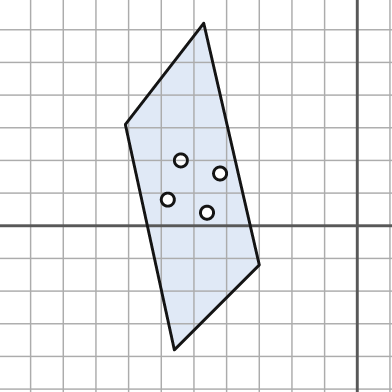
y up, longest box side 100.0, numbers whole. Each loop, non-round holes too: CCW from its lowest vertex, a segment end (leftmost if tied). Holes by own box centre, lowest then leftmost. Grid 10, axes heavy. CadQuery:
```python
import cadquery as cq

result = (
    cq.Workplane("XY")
    .moveTo(-56.0, -38.0)
    .lineTo(-30.0, -12.0)
    .lineTo(-47.0, 62.0)
    .lineTo(-71.0, 31.0)
    .close()
    .moveTo(-46.0, 4.0)
    .circle(2.0)
    .moveTo(-58.0, 8.0)
    .circle(2.0)
    .moveTo(-42.0, 16.0)
    .circle(2.0)
    .moveTo(-54.0, 20.0)
    .circle(2.0)
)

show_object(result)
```